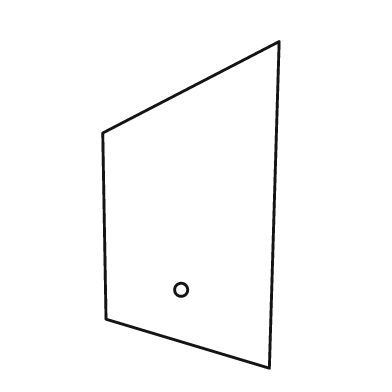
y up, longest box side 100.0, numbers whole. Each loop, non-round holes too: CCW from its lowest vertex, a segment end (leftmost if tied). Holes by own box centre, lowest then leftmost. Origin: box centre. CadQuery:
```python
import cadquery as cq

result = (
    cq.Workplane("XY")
    .moveTo(24.0, -50.0)
    .lineTo(27.0, 50.0)
    .lineTo(-27.0, 22.0)
    .lineTo(-26.0, -35.0)
    .close()
    .moveTo(-3.0, -26.0)
    .circle(2.0)
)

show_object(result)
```